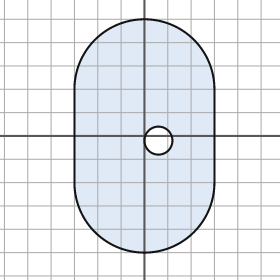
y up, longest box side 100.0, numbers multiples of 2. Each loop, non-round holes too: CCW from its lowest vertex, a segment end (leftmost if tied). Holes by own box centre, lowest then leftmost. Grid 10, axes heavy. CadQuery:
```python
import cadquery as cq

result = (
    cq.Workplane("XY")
    .moveTo(-30.0, -20.0)
    .threePointArc((0.0, -50.0), (30.0, -20.0))
    .lineTo(30.0, 20.0)
    .threePointArc((0.0, 50.0), (-30.0, 20.0))
    .close()
    .moveTo(6.0, -2.0)
    .circle(6.0)
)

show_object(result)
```